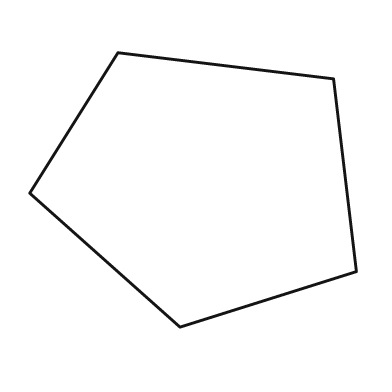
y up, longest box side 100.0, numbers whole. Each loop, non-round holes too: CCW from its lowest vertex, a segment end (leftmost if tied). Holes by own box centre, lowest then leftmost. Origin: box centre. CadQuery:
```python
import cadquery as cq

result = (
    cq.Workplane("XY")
    .moveTo(-4.0, -42.0)
    .lineTo(50.0, -25.0)
    .lineTo(43.0, 34.0)
    .lineTo(-23.0, 42.0)
    .lineTo(-50.0, -1.0)
    .close()
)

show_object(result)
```